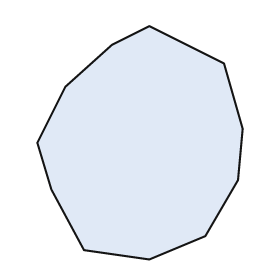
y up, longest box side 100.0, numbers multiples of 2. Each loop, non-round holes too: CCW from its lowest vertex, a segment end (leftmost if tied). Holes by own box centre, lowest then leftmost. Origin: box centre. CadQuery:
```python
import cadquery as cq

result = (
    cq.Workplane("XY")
    .moveTo(4.0, -50.0)
    .lineTo(28.0, -40.0)
    .lineTo(42.0, -16.0)
    .lineTo(44.0, 6.0)
    .lineTo(36.0, 34.0)
    .lineTo(4.0, 50.0)
    .lineTo(-12.0, 42.0)
    .lineTo(-32.0, 24.0)
    .lineTo(-44.0, 0.0)
    .lineTo(-38.0, -20.0)
    .lineTo(-24.0, -46.0)
    .close()
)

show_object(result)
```